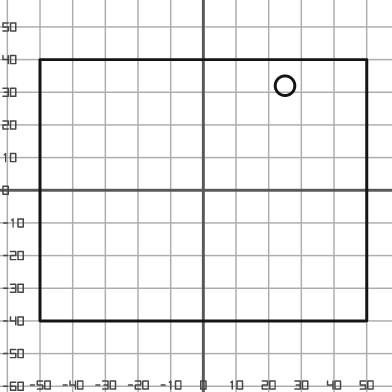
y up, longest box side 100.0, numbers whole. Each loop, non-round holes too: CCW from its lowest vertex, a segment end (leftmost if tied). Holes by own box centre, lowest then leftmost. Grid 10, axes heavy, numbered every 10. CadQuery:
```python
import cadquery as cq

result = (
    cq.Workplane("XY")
    .moveTo(-50.0, -40.0)
    .lineTo(50.0, -40.0)
    .lineTo(50.0, 40.0)
    .lineTo(-50.0, 40.0)
    .close()
    .moveTo(25.0, 32.0)
    .circle(3.0)
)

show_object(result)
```